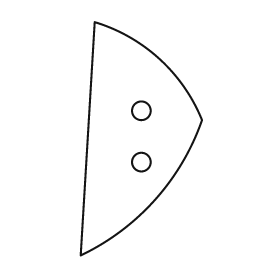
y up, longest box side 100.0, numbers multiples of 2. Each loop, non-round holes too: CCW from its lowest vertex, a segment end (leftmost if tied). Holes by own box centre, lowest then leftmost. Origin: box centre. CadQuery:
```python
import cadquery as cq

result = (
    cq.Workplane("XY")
    .moveTo(-26.0, -50.0)
    .threePointArc((6.0, -26.0), (26.0, 8.0))
    .threePointArc((8.0, 34.0), (-20.0, 50.0))
    .close()
    .moveTo(0.0, -10.0)
    .circle(4.0)
    .moveTo(0.0, 12.0)
    .circle(4.0)
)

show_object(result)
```